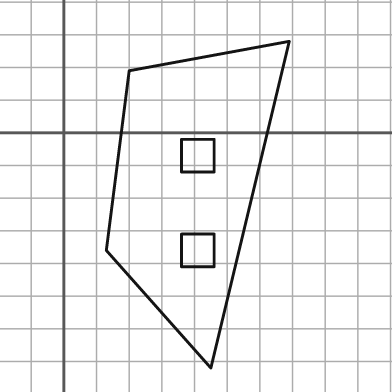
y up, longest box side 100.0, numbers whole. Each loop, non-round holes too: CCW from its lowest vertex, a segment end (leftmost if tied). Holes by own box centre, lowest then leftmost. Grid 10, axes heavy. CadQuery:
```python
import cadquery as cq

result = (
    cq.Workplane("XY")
    .moveTo(45.0, -72.0)
    .lineTo(69.0, 28.0)
    .lineTo(20.0, 19.0)
    .lineTo(13.0, -36.0)
    .close()
    .moveTo(36.0, -41.0)
    .lineTo(46.0, -41.0)
    .lineTo(46.0, -31.0)
    .lineTo(36.0, -31.0)
    .close()
    .moveTo(36.0, -12.0)
    .lineTo(46.0, -12.0)
    .lineTo(46.0, -2.0)
    .lineTo(36.0, -2.0)
    .close()
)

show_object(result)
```